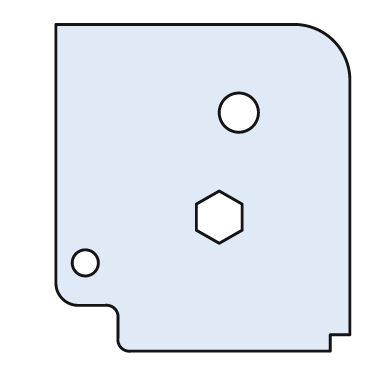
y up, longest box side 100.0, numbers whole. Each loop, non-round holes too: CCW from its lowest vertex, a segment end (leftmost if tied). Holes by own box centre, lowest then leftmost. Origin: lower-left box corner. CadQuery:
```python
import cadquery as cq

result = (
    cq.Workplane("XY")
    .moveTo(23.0, 0.0)
    .lineTo(84.0, 0.0)
    .lineTo(84.0, 5.0)
    .lineTo(90.0, 5.0)
    .lineTo(90.0, 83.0)
    .threePointArc((85.0, 95.0), (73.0, 100.0))
    .lineTo(0.0, 100.0)
    .lineTo(0.0, 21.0)
    .threePointArc((2.0, 16.0), (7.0, 14.0))
    .lineTo(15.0, 14.0)
    .threePointArc((18.0, 13.0), (19.0, 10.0))
    .lineTo(19.0, 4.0)
    .threePointArc((20.0, 1.0), (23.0, 0.0))
    .close()
    .moveTo(9.0, 27.0)
    .circle(4.0)
    .moveTo(50.0, 33.0)
    .lineTo(57.0, 37.0)
    .lineTo(57.0, 45.0)
    .lineTo(50.0, 49.0)
    .lineTo(43.0, 45.0)
    .lineTo(43.0, 37.0)
    .close()
    .moveTo(56.0, 73.0)
    .circle(6.0)
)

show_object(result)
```